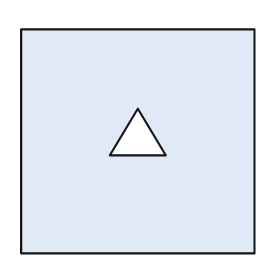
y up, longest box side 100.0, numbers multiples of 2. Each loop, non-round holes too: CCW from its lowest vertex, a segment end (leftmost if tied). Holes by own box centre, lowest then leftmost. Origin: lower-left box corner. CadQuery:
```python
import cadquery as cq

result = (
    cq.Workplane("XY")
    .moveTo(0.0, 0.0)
    .lineTo(100.0, 0.0)
    .lineTo(100.0, 96.0)
    .lineTo(0.0, 96.0)
    .close()
    .moveTo(38.0, 42.0)
    .lineTo(62.0, 42.0)
    .lineTo(50.0, 62.0)
    .close()
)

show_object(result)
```